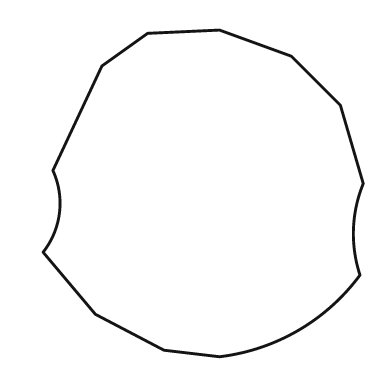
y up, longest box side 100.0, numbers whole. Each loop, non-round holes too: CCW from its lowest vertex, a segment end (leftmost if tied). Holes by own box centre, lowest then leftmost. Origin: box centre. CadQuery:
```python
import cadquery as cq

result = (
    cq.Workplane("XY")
    .moveTo(5.0, -50.0)
    .threePointArc((29.0, -42.0), (48.0, -25.0))
    .threePointArc((46.0, -11.0), (49.0, 3.0))
    .lineTo(42.0, 27.0)
    .lineTo(27.0, 42.0)
    .lineTo(5.0, 50.0)
    .lineTo(-17.0, 49.0)
    .lineTo(-31.0, 39.0)
    .lineTo(-46.0, 7.0)
    .threePointArc((-44.0, -6.0), (-49.0, -18.0))
    .lineTo(-33.0, -37.0)
    .lineTo(-12.0, -48.0)
    .close()
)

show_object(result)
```